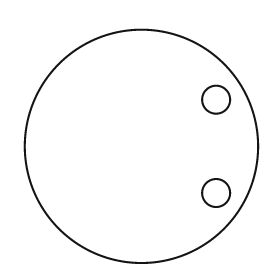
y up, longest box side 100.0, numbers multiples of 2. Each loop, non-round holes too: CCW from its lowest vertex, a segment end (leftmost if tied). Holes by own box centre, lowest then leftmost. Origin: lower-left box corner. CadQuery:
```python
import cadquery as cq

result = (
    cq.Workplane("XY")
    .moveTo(50.0, 50.0)
    .circle(50.0)
    .moveTo(82.0, 30.0)
    .circle(6.0)
    .moveTo(82.0, 70.0)
    .circle(6.0)
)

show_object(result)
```